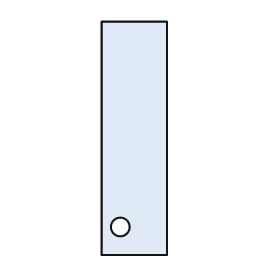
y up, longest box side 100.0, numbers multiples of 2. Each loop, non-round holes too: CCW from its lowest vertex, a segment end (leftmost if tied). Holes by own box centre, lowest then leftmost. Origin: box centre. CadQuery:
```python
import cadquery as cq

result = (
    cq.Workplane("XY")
    .moveTo(-14.0, -50.0)
    .lineTo(14.0, -50.0)
    .lineTo(14.0, 50.0)
    .lineTo(-14.0, 50.0)
    .close()
    .moveTo(-6.0, -38.0)
    .circle(4.0)
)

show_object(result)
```